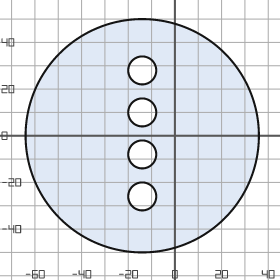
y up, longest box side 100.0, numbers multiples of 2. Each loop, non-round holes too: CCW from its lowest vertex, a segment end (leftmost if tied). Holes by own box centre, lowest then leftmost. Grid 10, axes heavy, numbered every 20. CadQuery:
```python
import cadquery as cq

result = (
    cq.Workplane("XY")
    .moveTo(-14.0, 0.0)
    .circle(50.0)
    .moveTo(-14.0, -26.0)
    .circle(6.0)
    .moveTo(-14.0, -8.0)
    .circle(6.0)
    .moveTo(-14.0, 10.0)
    .circle(6.0)
    .moveTo(-14.0, 28.0)
    .circle(6.0)
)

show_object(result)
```